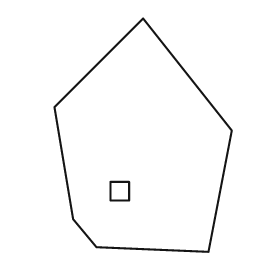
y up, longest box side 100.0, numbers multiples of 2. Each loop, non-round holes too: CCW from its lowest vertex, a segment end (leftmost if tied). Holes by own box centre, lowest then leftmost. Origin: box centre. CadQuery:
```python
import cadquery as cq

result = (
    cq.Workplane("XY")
    .moveTo(28.0, -50.0)
    .lineTo(38.0, 2.0)
    .lineTo(0.0, 50.0)
    .lineTo(-38.0, 12.0)
    .lineTo(-30.0, -36.0)
    .lineTo(-20.0, -48.0)
    .close()
    .moveTo(-14.0, -28.0)
    .lineTo(-6.0, -28.0)
    .lineTo(-6.0, -20.0)
    .lineTo(-14.0, -20.0)
    .close()
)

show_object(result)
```